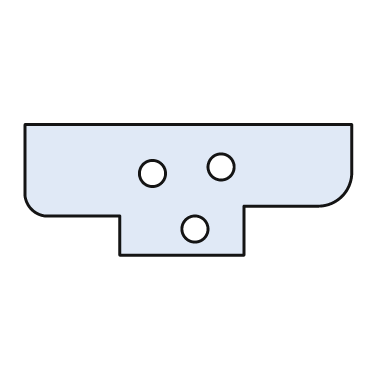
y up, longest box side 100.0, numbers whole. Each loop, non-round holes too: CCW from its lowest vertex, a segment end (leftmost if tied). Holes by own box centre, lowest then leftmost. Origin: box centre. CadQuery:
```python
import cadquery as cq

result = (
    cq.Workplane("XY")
    .moveTo(-21.0, -20.0)
    .lineTo(17.0, -20.0)
    .lineTo(17.0, -5.0)
    .lineTo(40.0, -5.0)
    .threePointArc((47.0, -2.0), (50.0, 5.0))
    .lineTo(50.0, 20.0)
    .lineTo(-50.0, 20.0)
    .lineTo(-50.0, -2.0)
    .threePointArc((-48.0, -6.0), (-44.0, -8.0))
    .lineTo(-21.0, -8.0)
    .close()
    .moveTo(2.0, -12.0)
    .circle(4.0)
    .moveTo(-11.0, 5.0)
    .circle(4.0)
    .moveTo(10.0, 7.0)
    .circle(4.0)
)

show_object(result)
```